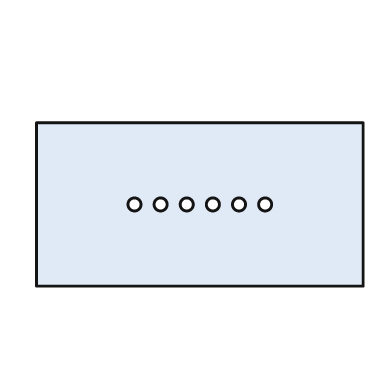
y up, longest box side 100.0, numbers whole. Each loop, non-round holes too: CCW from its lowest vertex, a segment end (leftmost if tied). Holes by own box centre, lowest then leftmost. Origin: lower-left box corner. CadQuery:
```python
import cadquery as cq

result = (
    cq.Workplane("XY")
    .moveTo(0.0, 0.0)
    .lineTo(100.0, 0.0)
    .lineTo(100.0, 50.0)
    .lineTo(0.0, 50.0)
    .close()
    .moveTo(30.0, 25.0)
    .circle(2.0)
    .moveTo(38.0, 25.0)
    .circle(2.0)
    .moveTo(46.0, 25.0)
    .circle(2.0)
    .moveTo(54.0, 25.0)
    .circle(2.0)
    .moveTo(62.0, 25.0)
    .circle(2.0)
    .moveTo(70.0, 25.0)
    .circle(2.0)
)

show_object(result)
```